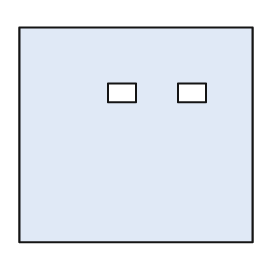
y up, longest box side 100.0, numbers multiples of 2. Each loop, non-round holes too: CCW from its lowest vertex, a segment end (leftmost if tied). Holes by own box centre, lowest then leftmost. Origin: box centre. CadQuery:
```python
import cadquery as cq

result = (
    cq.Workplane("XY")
    .moveTo(-50.0, -46.0)
    .lineTo(50.0, -46.0)
    .lineTo(50.0, 46.0)
    .lineTo(-50.0, 46.0)
    .close()
    .moveTo(-12.0, 14.0)
    .lineTo(0.0, 14.0)
    .lineTo(0.0, 22.0)
    .lineTo(-12.0, 22.0)
    .close()
    .moveTo(18.0, 14.0)
    .lineTo(30.0, 14.0)
    .lineTo(30.0, 22.0)
    .lineTo(18.0, 22.0)
    .close()
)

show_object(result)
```